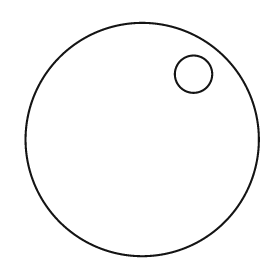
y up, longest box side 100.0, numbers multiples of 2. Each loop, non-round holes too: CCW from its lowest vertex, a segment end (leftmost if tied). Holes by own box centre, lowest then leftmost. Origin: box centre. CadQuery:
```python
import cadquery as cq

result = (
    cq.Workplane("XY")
    .moveTo(0.0, 0.0)
    .circle(50.0)
    .moveTo(22.0, 28.0)
    .circle(8.0)
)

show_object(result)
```